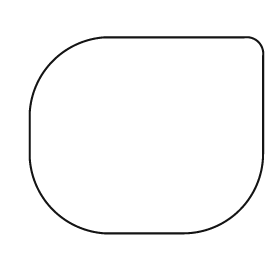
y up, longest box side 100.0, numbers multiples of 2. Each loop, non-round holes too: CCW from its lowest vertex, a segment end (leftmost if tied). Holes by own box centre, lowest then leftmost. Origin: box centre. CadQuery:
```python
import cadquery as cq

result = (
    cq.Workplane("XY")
    .moveTo(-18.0, -42.0)
    .lineTo(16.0, -42.0)
    .threePointArc((40.0, -32.0), (50.0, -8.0))
    .lineTo(50.0, 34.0)
    .threePointArc((48.0, 40.0), (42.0, 42.0))
    .lineTo(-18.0, 42.0)
    .threePointArc((-40.0, 32.0), (-50.0, 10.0))
    .lineTo(-50.0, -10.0)
    .threePointArc((-40.0, -32.0), (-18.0, -42.0))
    .close()
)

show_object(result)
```